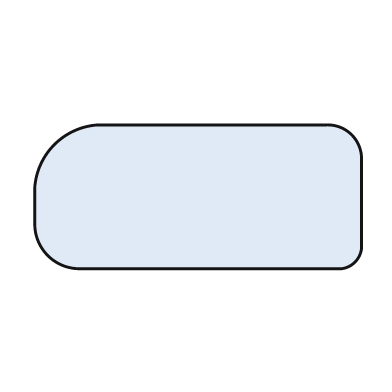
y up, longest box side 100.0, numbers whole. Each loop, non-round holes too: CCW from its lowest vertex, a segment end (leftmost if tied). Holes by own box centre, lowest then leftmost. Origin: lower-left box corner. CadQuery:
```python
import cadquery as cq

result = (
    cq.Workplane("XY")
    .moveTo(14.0, 0.0)
    .lineTo(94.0, 0.0)
    .threePointArc((98.0, 2.0), (100.0, 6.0))
    .lineTo(100.0, 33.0)
    .threePointArc((97.0, 41.0), (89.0, 44.0))
    .lineTo(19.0, 44.0)
    .threePointArc((6.0, 38.0), (0.0, 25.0))
    .lineTo(0.0, 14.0)
    .threePointArc((4.0, 4.0), (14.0, 0.0))
    .close()
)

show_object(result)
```